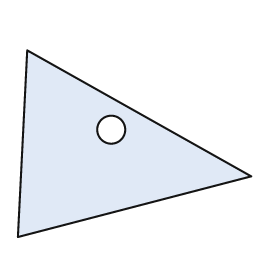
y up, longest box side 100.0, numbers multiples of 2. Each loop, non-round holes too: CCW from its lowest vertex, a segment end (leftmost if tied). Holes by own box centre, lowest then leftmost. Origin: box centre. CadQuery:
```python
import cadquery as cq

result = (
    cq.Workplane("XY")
    .moveTo(-50.0, -40.0)
    .lineTo(50.0, -14.0)
    .lineTo(-46.0, 40.0)
    .close()
    .moveTo(-10.0, 6.0)
    .circle(6.0)
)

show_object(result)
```